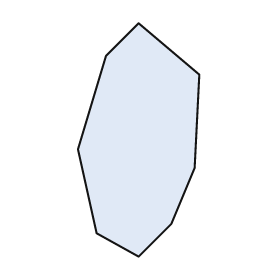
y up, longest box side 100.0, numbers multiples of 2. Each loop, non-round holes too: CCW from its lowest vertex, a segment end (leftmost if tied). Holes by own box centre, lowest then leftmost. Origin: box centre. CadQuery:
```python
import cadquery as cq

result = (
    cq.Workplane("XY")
    .moveTo(0.0, -50.0)
    .lineTo(14.0, -36.0)
    .lineTo(24.0, -12.0)
    .lineTo(26.0, 28.0)
    .lineTo(0.0, 50.0)
    .lineTo(-14.0, 36.0)
    .lineTo(-26.0, -4.0)
    .lineTo(-18.0, -40.0)
    .close()
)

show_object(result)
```